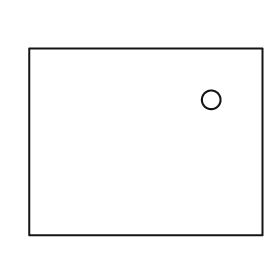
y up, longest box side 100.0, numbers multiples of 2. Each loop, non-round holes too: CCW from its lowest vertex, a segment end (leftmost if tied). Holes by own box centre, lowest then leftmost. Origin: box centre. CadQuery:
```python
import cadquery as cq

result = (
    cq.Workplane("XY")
    .moveTo(-50.0, -40.0)
    .lineTo(50.0, -40.0)
    .lineTo(50.0, 40.0)
    .lineTo(-50.0, 40.0)
    .close()
    .moveTo(28.0, 18.0)
    .circle(4.0)
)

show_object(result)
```